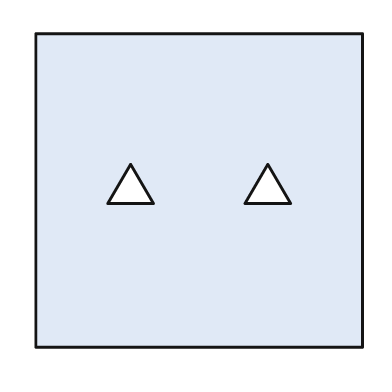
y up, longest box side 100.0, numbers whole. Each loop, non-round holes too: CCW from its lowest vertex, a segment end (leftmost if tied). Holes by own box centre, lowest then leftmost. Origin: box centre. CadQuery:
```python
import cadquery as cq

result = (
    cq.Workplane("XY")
    .moveTo(-50.0, -48.0)
    .lineTo(50.0, -48.0)
    .lineTo(50.0, 48.0)
    .lineTo(-50.0, 48.0)
    .close()
    .moveTo(-28.0, -4.0)
    .lineTo(-14.0, -4.0)
    .lineTo(-21.0, 8.0)
    .close()
    .moveTo(14.0, -4.0)
    .lineTo(28.0, -4.0)
    .lineTo(21.0, 8.0)
    .close()
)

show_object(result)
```